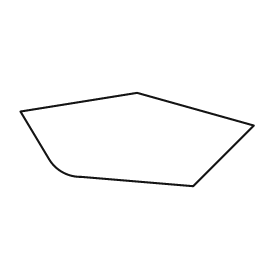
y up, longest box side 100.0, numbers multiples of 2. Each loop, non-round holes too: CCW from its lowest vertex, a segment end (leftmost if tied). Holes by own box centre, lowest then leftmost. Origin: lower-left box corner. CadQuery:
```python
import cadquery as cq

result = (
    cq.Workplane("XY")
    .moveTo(74.0, 0.0)
    .lineTo(100.0, 26.0)
    .lineTo(50.0, 40.0)
    .lineTo(0.0, 32.0)
    .lineTo(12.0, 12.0)
    .threePointArc((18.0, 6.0), (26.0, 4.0))
    .close()
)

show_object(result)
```